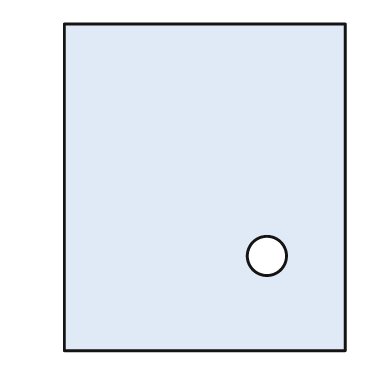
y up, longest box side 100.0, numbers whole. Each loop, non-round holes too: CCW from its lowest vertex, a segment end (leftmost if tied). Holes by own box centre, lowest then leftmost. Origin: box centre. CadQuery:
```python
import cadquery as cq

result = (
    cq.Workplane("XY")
    .moveTo(-43.0, -50.0)
    .lineTo(43.0, -50.0)
    .lineTo(43.0, 50.0)
    .lineTo(-43.0, 50.0)
    .close()
    .moveTo(19.0, -21.0)
    .circle(6.0)
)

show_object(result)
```